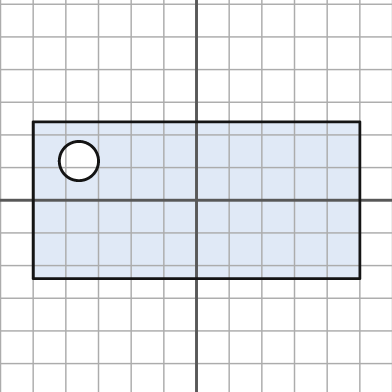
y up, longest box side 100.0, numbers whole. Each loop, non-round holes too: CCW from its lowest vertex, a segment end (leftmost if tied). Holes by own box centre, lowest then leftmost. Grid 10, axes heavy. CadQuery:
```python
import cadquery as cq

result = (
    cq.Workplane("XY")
    .moveTo(-50.0, -24.0)
    .lineTo(50.0, -24.0)
    .lineTo(50.0, 24.0)
    .lineTo(-50.0, 24.0)
    .close()
    .moveTo(-36.0, 12.0)
    .circle(6.0)
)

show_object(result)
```